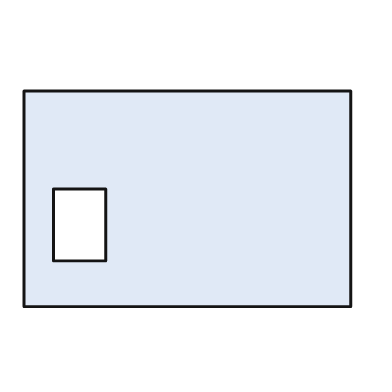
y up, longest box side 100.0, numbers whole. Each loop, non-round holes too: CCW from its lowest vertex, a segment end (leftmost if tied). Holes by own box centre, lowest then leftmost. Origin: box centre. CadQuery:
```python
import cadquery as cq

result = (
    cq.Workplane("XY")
    .moveTo(-50.0, -33.0)
    .lineTo(50.0, -33.0)
    .lineTo(50.0, 33.0)
    .lineTo(-50.0, 33.0)
    .close()
    .moveTo(-41.0, -19.0)
    .lineTo(-25.0, -19.0)
    .lineTo(-25.0, 3.0)
    .lineTo(-41.0, 3.0)
    .close()
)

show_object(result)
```